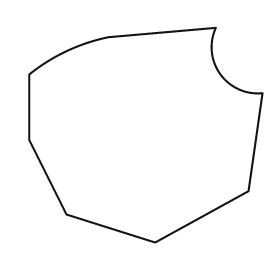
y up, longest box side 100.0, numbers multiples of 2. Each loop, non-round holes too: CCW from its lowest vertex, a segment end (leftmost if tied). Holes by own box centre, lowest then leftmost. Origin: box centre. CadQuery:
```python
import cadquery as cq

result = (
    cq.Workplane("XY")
    .moveTo(4.0, -46.0)
    .lineTo(44.0, -24.0)
    .lineTo(50.0, 18.0)
    .threePointArc((32.0, 26.0), (30.0, 46.0))
    .lineTo(-16.0, 42.0)
    .threePointArc((-34.0, 36.0), (-50.0, 26.0))
    .lineTo(-50.0, -2.0)
    .lineTo(-34.0, -34.0)
    .close()
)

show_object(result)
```